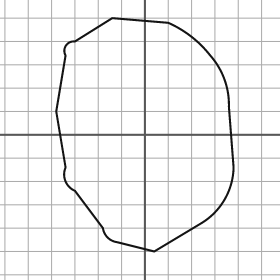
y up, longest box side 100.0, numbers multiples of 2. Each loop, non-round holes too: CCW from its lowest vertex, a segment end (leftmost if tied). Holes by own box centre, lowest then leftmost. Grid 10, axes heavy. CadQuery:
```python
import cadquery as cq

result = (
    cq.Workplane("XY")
    .moveTo(4.0, -50.0)
    .lineTo(24.0, -38.0)
    .threePointArc((34.0, -28.0), (38.0, -14.0))
    .lineTo(36.0, 12.0)
    .threePointArc((34.0, 24.0), (28.0, 34.0))
    .threePointArc((20.0, 42.0), (10.0, 48.0))
    .lineTo(-14.0, 50.0)
    .lineTo(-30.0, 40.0)
    .threePointArc((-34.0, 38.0), (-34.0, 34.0))
    .lineTo(-38.0, 10.0)
    .lineTo(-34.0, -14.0)
    .threePointArc((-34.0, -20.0), (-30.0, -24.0))
    .lineTo(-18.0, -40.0)
    .threePointArc((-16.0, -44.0), (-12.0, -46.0))
    .close()
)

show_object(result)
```